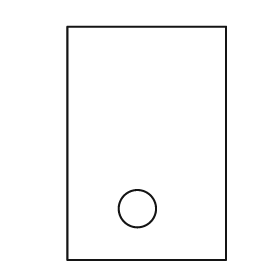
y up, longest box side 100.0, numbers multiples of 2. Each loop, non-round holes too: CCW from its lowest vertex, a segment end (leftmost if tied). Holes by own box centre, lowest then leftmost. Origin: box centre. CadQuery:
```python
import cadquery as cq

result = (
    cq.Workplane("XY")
    .moveTo(-34.0, -50.0)
    .lineTo(34.0, -50.0)
    .lineTo(34.0, 50.0)
    .lineTo(-34.0, 50.0)
    .close()
    .moveTo(-4.0, -28.0)
    .circle(8.0)
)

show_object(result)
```